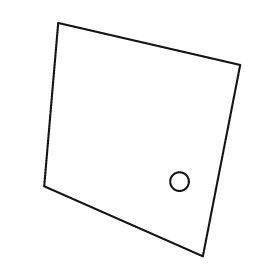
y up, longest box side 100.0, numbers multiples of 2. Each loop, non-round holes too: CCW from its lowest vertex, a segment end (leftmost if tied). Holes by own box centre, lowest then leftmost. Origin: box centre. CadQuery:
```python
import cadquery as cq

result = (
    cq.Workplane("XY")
    .moveTo(26.0, -50.0)
    .lineTo(42.0, 32.0)
    .lineTo(-36.0, 50.0)
    .lineTo(-42.0, -20.0)
    .close()
    .moveTo(16.0, -18.0)
    .circle(4.0)
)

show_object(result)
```